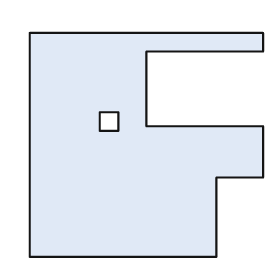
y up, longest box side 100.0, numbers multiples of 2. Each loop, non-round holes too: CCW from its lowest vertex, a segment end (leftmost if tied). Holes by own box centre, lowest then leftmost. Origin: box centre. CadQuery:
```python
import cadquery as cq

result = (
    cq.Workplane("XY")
    .moveTo(-50.0, -48.0)
    .lineTo(30.0, -48.0)
    .lineTo(30.0, -14.0)
    .lineTo(50.0, -14.0)
    .lineTo(50.0, 8.0)
    .lineTo(0.0, 8.0)
    .lineTo(0.0, 40.0)
    .lineTo(50.0, 40.0)
    .lineTo(50.0, 48.0)
    .lineTo(-50.0, 48.0)
    .close()
    .moveTo(-20.0, 6.0)
    .lineTo(-12.0, 6.0)
    .lineTo(-12.0, 14.0)
    .lineTo(-20.0, 14.0)
    .close()
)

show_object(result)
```